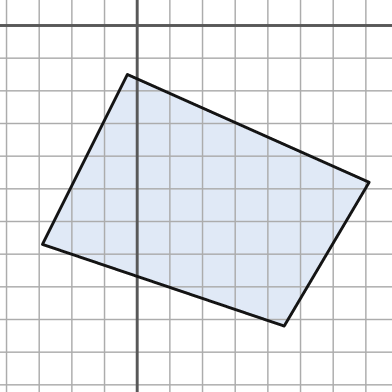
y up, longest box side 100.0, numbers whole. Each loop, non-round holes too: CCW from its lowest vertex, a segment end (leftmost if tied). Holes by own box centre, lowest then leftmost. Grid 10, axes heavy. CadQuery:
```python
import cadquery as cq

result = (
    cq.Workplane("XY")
    .moveTo(45.0, -92.0)
    .lineTo(71.0, -48.0)
    .lineTo(-3.0, -15.0)
    .lineTo(-29.0, -67.0)
    .close()
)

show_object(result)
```